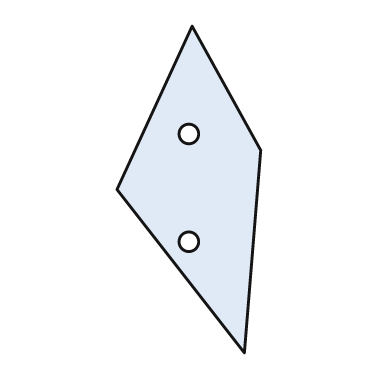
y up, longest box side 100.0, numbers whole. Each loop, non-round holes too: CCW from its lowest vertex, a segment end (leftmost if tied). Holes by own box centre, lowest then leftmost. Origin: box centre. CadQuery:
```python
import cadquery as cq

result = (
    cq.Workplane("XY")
    .moveTo(17.0, -50.0)
    .lineTo(22.0, 12.0)
    .lineTo(1.0, 50.0)
    .lineTo(-22.0, 0.0)
    .close()
    .moveTo(0.0, -16.0)
    .circle(3.0)
    .moveTo(0.0, 17.0)
    .circle(3.0)
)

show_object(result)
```